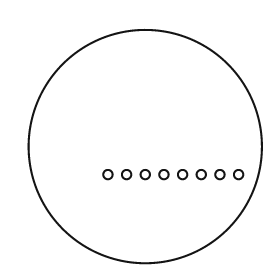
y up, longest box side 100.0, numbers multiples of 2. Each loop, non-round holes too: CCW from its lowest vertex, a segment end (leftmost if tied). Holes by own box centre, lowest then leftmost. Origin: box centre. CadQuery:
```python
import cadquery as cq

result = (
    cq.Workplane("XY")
    .moveTo(0.0, 0.0)
    .circle(50.0)
    .moveTo(-16.0, -12.0)
    .circle(2.0)
    .moveTo(-8.0, -12.0)
    .circle(2.0)
    .moveTo(0.0, -12.0)
    .circle(2.0)
    .moveTo(8.0, -12.0)
    .circle(2.0)
    .moveTo(16.0, -12.0)
    .circle(2.0)
    .moveTo(24.0, -12.0)
    .circle(2.0)
    .moveTo(32.0, -12.0)
    .circle(2.0)
    .moveTo(40.0, -12.0)
    .circle(2.0)
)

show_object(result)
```